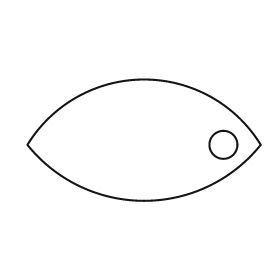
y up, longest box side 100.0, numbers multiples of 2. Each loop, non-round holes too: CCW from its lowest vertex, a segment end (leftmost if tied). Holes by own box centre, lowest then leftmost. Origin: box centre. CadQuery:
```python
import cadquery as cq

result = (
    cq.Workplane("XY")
    .moveTo(-50.0, -2.0)
    .threePointArc((0.0, -26.0), (50.0, -2.0))
    .threePointArc((0.0, 26.0), (-50.0, -2.0))
    .close()
    .moveTo(34.0, -2.0)
    .circle(6.0)
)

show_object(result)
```